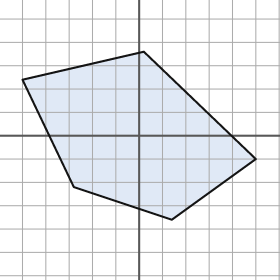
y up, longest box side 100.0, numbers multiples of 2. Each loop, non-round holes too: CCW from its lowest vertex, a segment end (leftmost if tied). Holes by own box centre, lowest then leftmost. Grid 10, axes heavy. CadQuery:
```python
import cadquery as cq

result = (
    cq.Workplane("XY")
    .moveTo(14.0, -36.0)
    .lineTo(50.0, -10.0)
    .lineTo(2.0, 36.0)
    .lineTo(-50.0, 24.0)
    .lineTo(-28.0, -22.0)
    .close()
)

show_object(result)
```